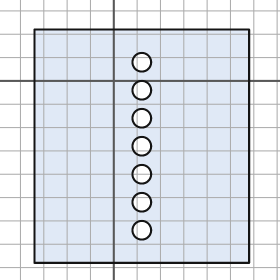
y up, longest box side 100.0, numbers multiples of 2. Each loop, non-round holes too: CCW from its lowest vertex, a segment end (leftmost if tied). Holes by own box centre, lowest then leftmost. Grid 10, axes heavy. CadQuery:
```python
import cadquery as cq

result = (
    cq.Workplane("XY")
    .moveTo(-34.0, -78.0)
    .lineTo(58.0, -78.0)
    .lineTo(58.0, 22.0)
    .lineTo(-34.0, 22.0)
    .close()
    .moveTo(12.0, -64.0)
    .circle(4.0)
    .moveTo(12.0, -52.0)
    .circle(4.0)
    .moveTo(12.0, -40.0)
    .circle(4.0)
    .moveTo(12.0, -28.0)
    .circle(4.0)
    .moveTo(12.0, -16.0)
    .circle(4.0)
    .moveTo(12.0, -4.0)
    .circle(4.0)
    .moveTo(12.0, 8.0)
    .circle(4.0)
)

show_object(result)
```